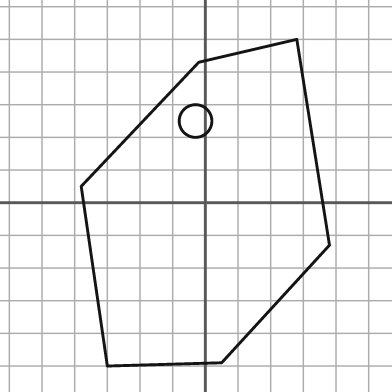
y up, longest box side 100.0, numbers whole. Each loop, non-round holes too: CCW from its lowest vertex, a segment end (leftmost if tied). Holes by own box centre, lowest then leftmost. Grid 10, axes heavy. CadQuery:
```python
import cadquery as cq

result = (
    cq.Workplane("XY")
    .moveTo(-30.0, -50.0)
    .lineTo(5.0, -49.0)
    .lineTo(38.0, -13.0)
    .lineTo(28.0, 50.0)
    .lineTo(-2.0, 43.0)
    .lineTo(-38.0, 5.0)
    .close()
    .moveTo(-3.0, 25.0)
    .circle(5.0)
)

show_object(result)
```